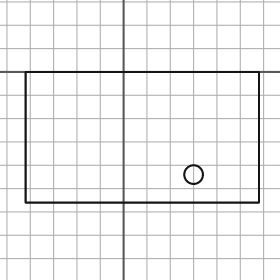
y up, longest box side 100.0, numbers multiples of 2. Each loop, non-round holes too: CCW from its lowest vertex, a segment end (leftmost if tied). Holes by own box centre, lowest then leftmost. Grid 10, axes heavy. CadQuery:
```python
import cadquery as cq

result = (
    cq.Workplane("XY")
    .moveTo(-42.0, -56.0)
    .lineTo(58.0, -56.0)
    .lineTo(58.0, 0.0)
    .lineTo(-42.0, 0.0)
    .close()
    .moveTo(30.0, -44.0)
    .circle(4.0)
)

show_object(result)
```